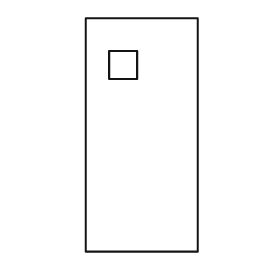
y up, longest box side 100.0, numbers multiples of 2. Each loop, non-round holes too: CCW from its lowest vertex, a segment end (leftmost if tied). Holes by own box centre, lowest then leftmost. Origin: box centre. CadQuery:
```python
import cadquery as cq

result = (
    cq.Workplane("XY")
    .moveTo(-24.0, -50.0)
    .lineTo(24.0, -50.0)
    .lineTo(24.0, 50.0)
    .lineTo(-24.0, 50.0)
    .close()
    .moveTo(-14.0, 24.0)
    .lineTo(-2.0, 24.0)
    .lineTo(-2.0, 36.0)
    .lineTo(-14.0, 36.0)
    .close()
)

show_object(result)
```